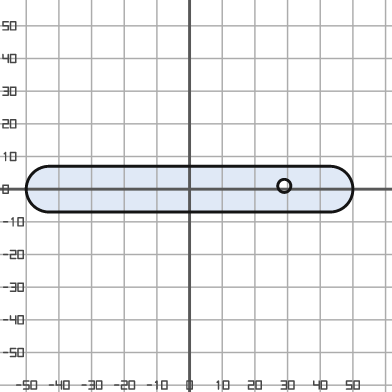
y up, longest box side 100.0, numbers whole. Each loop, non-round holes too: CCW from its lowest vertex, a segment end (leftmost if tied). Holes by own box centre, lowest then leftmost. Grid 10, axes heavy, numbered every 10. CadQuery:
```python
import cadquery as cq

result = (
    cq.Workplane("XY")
    .moveTo(-43.0, -7.0)
    .lineTo(43.0, -7.0)
    .threePointArc((50.0, 0.0), (43.0, 7.0))
    .lineTo(-43.0, 7.0)
    .threePointArc((-50.0, 0.0), (-43.0, -7.0))
    .close()
    .moveTo(29.0, 1.0)
    .circle(2.0)
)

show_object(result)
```